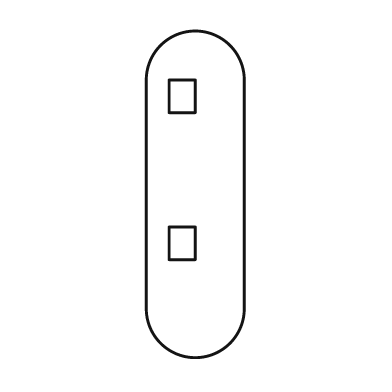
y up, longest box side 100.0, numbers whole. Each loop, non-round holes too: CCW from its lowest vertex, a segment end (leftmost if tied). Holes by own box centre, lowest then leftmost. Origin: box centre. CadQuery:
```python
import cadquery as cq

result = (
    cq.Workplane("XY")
    .moveTo(-15.0, -35.0)
    .threePointArc((0.0, -50.0), (15.0, -35.0))
    .lineTo(15.0, 35.0)
    .threePointArc((0.0, 50.0), (-15.0, 35.0))
    .close()
    .moveTo(-8.0, -20.0)
    .lineTo(0.0, -20.0)
    .lineTo(0.0, -10.0)
    .lineTo(-8.0, -10.0)
    .close()
    .moveTo(-8.0, 25.0)
    .lineTo(0.0, 25.0)
    .lineTo(0.0, 35.0)
    .lineTo(-8.0, 35.0)
    .close()
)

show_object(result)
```